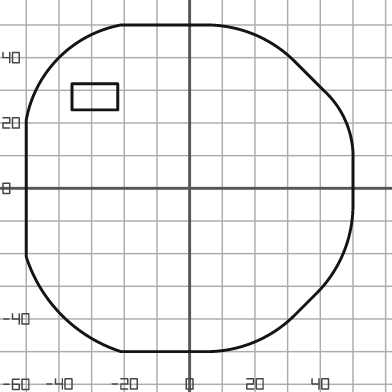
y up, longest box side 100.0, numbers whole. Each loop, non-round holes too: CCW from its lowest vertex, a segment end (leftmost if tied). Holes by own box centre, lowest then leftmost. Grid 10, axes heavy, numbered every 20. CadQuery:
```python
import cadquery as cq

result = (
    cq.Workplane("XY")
    .moveTo(-21.0, -50.0)
    .lineTo(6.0, -50.0)
    .threePointArc((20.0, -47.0), (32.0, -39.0))
    .lineTo(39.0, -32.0)
    .threePointArc((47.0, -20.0), (50.0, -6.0))
    .lineTo(50.0, 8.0)
    .threePointArc((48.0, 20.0), (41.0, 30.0))
    .lineTo(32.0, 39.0)
    .threePointArc((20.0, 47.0), (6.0, 50.0))
    .lineTo(-21.0, 50.0)
    .threePointArc((-40.0, 40.0), (-50.0, 21.0))
    .lineTo(-50.0, -21.0)
    .threePointArc((-39.0, -39.0), (-21.0, -50.0))
    .close()
    .moveTo(-36.0, 24.0)
    .lineTo(-22.0, 24.0)
    .lineTo(-22.0, 32.0)
    .lineTo(-36.0, 32.0)
    .close()
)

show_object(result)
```